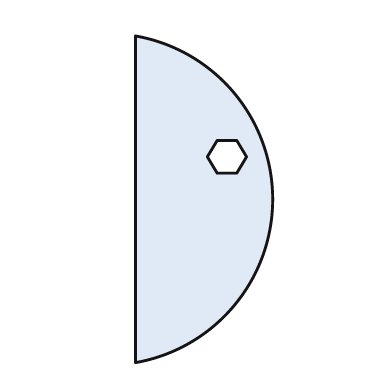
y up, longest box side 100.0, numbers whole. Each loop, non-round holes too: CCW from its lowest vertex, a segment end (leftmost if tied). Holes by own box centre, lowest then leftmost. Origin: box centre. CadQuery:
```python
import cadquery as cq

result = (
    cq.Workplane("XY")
    .moveTo(-21.0, -50.0)
    .threePointArc((21.0, 0.0), (-21.0, 50.0))
    .close()
    .moveTo(4.0, 8.0)
    .lineTo(10.0, 8.0)
    .lineTo(13.0, 13.0)
    .lineTo(10.0, 18.0)
    .lineTo(4.0, 18.0)
    .lineTo(1.0, 13.0)
    .close()
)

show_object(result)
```